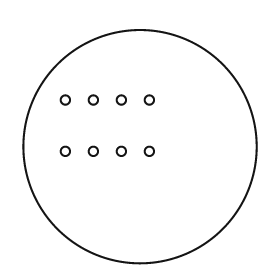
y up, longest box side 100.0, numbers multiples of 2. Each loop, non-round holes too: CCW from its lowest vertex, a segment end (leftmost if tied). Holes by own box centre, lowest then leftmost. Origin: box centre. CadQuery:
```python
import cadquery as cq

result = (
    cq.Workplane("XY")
    .moveTo(0.0, 0.0)
    .circle(50.0)
    .moveTo(-32.0, -2.0)
    .circle(2.0)
    .moveTo(-20.0, -2.0)
    .circle(2.0)
    .moveTo(-8.0, -2.0)
    .circle(2.0)
    .moveTo(4.0, -2.0)
    .circle(2.0)
    .moveTo(-32.0, 20.0)
    .circle(2.0)
    .moveTo(-20.0, 20.0)
    .circle(2.0)
    .moveTo(-8.0, 20.0)
    .circle(2.0)
    .moveTo(4.0, 20.0)
    .circle(2.0)
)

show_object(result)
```